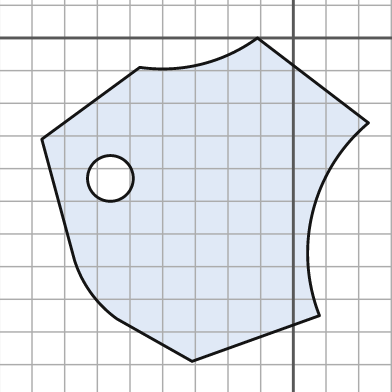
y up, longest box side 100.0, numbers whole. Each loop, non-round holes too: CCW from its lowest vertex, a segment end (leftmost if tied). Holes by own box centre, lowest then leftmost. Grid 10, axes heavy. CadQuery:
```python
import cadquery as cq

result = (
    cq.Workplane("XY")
    .moveTo(-31.0, -99.0)
    .lineTo(8.0, -85.0)
    .threePointArc((6.0, -53.0), (23.0, -26.0))
    .lineTo(-11.0, 0.0)
    .threePointArc((-28.0, -8.0), (-47.0, -9.0))
    .lineTo(-77.0, -31.0)
    .lineTo(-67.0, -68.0)
    .threePointArc((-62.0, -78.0), (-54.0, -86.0))
    .close()
    .moveTo(-56.0, -43.0)
    .circle(7.0)
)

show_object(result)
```